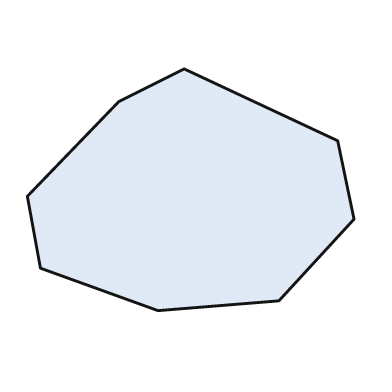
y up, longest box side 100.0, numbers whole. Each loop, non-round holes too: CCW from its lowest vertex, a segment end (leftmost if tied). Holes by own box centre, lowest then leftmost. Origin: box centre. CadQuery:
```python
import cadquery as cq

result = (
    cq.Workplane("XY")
    .moveTo(-10.0, -37.0)
    .lineTo(27.0, -34.0)
    .lineTo(50.0, -9.0)
    .lineTo(45.0, 15.0)
    .lineTo(-2.0, 37.0)
    .lineTo(-22.0, 27.0)
    .lineTo(-50.0, -2.0)
    .lineTo(-46.0, -24.0)
    .close()
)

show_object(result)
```